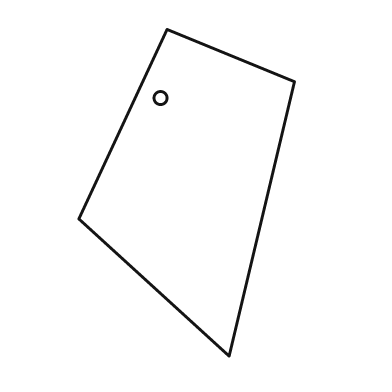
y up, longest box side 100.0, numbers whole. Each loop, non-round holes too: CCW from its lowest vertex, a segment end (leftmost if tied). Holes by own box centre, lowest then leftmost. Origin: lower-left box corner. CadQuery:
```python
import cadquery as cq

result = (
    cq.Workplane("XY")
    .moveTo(46.0, 0.0)
    .lineTo(66.0, 84.0)
    .lineTo(27.0, 100.0)
    .lineTo(0.0, 42.0)
    .close()
    .moveTo(25.0, 79.0)
    .circle(2.0)
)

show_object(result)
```